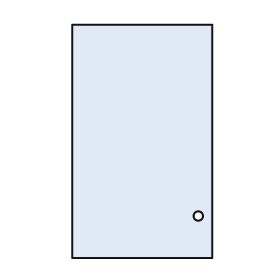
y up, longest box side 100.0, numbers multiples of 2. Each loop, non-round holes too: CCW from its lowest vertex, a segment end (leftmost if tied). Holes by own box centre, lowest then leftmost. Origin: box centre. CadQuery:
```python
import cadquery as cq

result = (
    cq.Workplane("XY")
    .moveTo(-30.0, -50.0)
    .lineTo(30.0, -50.0)
    .lineTo(30.0, 50.0)
    .lineTo(-30.0, 50.0)
    .close()
    .moveTo(24.0, -32.0)
    .circle(2.0)
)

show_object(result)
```